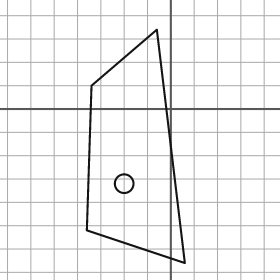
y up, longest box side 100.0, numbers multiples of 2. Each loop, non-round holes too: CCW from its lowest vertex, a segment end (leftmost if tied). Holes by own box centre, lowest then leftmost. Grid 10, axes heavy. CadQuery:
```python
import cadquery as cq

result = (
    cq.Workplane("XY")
    .moveTo(6.0, -66.0)
    .lineTo(-6.0, 34.0)
    .lineTo(-34.0, 10.0)
    .lineTo(-36.0, -52.0)
    .close()
    .moveTo(-20.0, -32.0)
    .circle(4.0)
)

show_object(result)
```